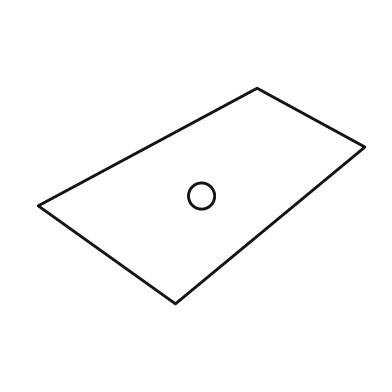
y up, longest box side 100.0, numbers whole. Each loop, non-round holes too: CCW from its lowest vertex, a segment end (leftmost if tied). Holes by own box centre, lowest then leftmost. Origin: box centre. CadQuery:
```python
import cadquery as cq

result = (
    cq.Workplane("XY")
    .moveTo(-8.0, -33.0)
    .lineTo(50.0, 15.0)
    .lineTo(17.0, 33.0)
    .lineTo(-50.0, -3.0)
    .close()
    .moveTo(0.0, 0.0)
    .circle(4.0)
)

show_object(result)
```